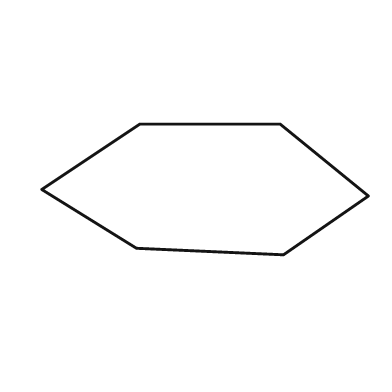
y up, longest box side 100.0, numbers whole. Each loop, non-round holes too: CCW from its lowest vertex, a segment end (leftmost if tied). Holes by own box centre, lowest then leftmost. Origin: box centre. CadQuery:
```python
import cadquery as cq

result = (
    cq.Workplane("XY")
    .moveTo(24.0, -20.0)
    .lineTo(50.0, -2.0)
    .lineTo(23.0, 20.0)
    .lineTo(-20.0, 20.0)
    .lineTo(-50.0, 0.0)
    .lineTo(-21.0, -18.0)
    .close()
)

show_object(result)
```